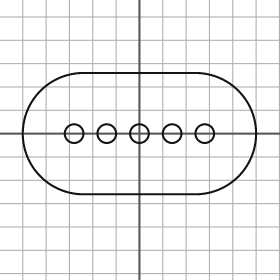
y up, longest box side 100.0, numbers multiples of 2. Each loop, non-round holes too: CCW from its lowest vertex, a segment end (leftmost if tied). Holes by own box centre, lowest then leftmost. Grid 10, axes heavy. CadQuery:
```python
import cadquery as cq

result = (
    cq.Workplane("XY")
    .moveTo(-24.0, -26.0)
    .lineTo(24.0, -26.0)
    .threePointArc((50.0, 0.0), (24.0, 26.0))
    .lineTo(-24.0, 26.0)
    .threePointArc((-50.0, 0.0), (-24.0, -26.0))
    .close()
    .moveTo(-28.0, 0.0)
    .circle(4.0)
    .moveTo(-14.0, 0.0)
    .circle(4.0)
    .moveTo(0.0, 0.0)
    .circle(4.0)
    .moveTo(14.0, 0.0)
    .circle(4.0)
    .moveTo(28.0, 0.0)
    .circle(4.0)
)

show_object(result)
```